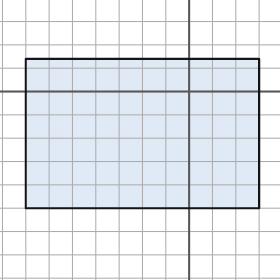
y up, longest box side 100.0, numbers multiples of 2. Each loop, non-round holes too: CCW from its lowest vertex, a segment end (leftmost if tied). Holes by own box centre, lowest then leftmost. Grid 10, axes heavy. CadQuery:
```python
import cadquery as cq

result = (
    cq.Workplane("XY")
    .moveTo(-70.0, -50.0)
    .lineTo(30.0, -50.0)
    .lineTo(30.0, 14.0)
    .lineTo(-70.0, 14.0)
    .close()
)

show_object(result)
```